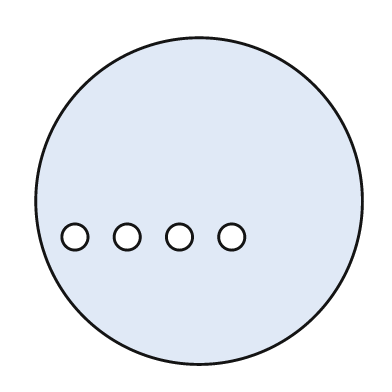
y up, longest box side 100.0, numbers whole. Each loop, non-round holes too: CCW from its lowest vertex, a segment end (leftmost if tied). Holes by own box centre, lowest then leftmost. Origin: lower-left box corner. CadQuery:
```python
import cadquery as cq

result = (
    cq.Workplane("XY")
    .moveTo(50.0, 50.0)
    .circle(50.0)
    .moveTo(12.0, 39.0)
    .circle(4.0)
    .moveTo(28.0, 39.0)
    .circle(4.0)
    .moveTo(44.0, 39.0)
    .circle(4.0)
    .moveTo(60.0, 39.0)
    .circle(4.0)
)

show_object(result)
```